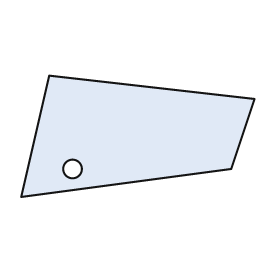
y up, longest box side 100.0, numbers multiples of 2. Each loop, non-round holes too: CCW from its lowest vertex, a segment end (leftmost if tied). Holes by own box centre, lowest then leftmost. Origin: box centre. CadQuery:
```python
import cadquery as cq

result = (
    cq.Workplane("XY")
    .moveTo(-50.0, -26.0)
    .lineTo(40.0, -14.0)
    .lineTo(50.0, 16.0)
    .lineTo(-38.0, 26.0)
    .close()
    .moveTo(-28.0, -14.0)
    .circle(4.0)
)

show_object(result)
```